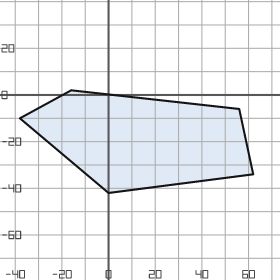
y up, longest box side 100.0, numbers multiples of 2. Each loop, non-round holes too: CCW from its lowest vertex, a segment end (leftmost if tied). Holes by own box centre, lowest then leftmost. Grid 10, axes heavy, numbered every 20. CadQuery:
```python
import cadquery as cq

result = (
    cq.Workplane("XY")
    .moveTo(0.0, -42.0)
    .lineTo(62.0, -34.0)
    .lineTo(56.0, -6.0)
    .lineTo(-16.0, 2.0)
    .lineTo(-38.0, -10.0)
    .close()
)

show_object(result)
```